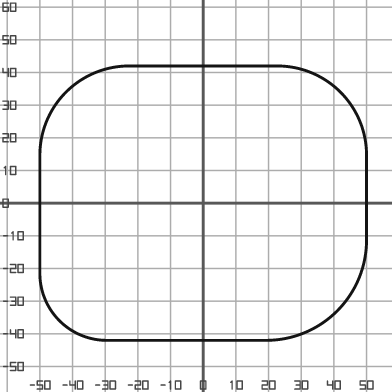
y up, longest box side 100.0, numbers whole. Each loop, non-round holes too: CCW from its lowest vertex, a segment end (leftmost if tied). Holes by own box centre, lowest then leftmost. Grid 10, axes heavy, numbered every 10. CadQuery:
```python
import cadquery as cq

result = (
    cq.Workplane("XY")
    .moveTo(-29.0, -42.0)
    .lineTo(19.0, -42.0)
    .threePointArc((41.0, -33.0), (50.0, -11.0))
    .lineTo(50.0, 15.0)
    .threePointArc((42.0, 34.0), (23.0, 42.0))
    .lineTo(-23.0, 42.0)
    .threePointArc((-42.0, 34.0), (-50.0, 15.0))
    .lineTo(-50.0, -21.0)
    .threePointArc((-44.0, -36.0), (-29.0, -42.0))
    .close()
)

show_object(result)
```